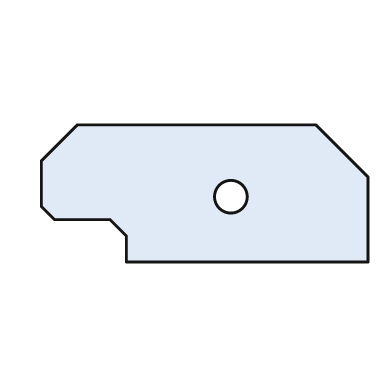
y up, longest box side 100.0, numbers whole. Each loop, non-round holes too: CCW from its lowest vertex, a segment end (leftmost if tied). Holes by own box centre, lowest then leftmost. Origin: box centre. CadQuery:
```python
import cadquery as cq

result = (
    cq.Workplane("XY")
    .moveTo(-24.0, -21.0)
    .lineTo(50.0, -21.0)
    .lineTo(50.0, 5.0)
    .lineTo(34.0, 21.0)
    .lineTo(-39.0, 21.0)
    .lineTo(-50.0, 10.0)
    .lineTo(-50.0, -4.0)
    .lineTo(-46.0, -8.0)
    .lineTo(-29.0, -8.0)
    .lineTo(-24.0, -13.0)
    .close()
    .moveTo(8.0, -1.0)
    .circle(5.0)
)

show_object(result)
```